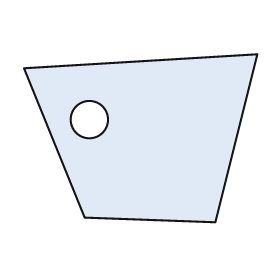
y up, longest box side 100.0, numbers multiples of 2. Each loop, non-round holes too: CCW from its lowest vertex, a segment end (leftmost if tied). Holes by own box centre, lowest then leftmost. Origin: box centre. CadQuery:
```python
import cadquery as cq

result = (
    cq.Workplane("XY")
    .moveTo(32.0, -36.0)
    .lineTo(50.0, 36.0)
    .lineTo(-50.0, 30.0)
    .lineTo(-24.0, -34.0)
    .close()
    .moveTo(-22.0, 8.0)
    .circle(8.0)
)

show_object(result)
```